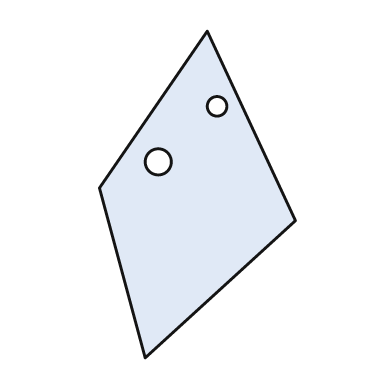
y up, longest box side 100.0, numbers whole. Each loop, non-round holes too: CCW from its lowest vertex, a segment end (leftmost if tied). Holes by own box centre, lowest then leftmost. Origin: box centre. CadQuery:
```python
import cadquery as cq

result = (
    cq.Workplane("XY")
    .moveTo(-16.0, -50.0)
    .lineTo(30.0, -8.0)
    .lineTo(3.0, 50.0)
    .lineTo(-30.0, 2.0)
    .close()
    .moveTo(-12.0, 10.0)
    .circle(4.0)
    .moveTo(6.0, 27.0)
    .circle(3.0)
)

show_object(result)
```